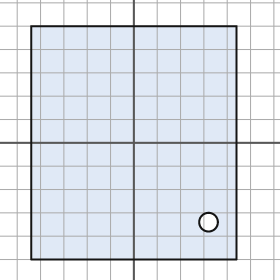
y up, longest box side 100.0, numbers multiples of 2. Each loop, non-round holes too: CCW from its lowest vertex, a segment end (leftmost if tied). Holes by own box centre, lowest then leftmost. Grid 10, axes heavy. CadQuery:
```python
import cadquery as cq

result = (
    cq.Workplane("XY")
    .moveTo(-44.0, -50.0)
    .lineTo(44.0, -50.0)
    .lineTo(44.0, 50.0)
    .lineTo(-44.0, 50.0)
    .close()
    .moveTo(32.0, -34.0)
    .circle(4.0)
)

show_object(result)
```